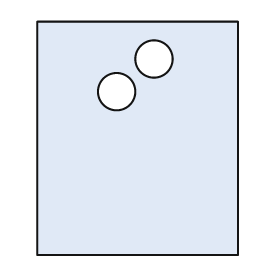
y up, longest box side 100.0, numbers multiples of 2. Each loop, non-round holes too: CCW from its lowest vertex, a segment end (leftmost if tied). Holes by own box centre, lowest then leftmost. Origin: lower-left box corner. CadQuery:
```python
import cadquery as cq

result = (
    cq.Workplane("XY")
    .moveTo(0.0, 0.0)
    .lineTo(86.0, 0.0)
    .lineTo(86.0, 100.0)
    .lineTo(0.0, 100.0)
    .close()
    .moveTo(34.0, 70.0)
    .circle(8.0)
    .moveTo(50.0, 84.0)
    .circle(8.0)
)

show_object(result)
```